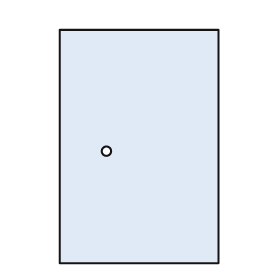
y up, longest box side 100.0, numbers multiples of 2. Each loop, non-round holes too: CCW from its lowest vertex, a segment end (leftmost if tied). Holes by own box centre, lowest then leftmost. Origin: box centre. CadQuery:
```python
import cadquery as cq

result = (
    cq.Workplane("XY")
    .moveTo(-34.0, -50.0)
    .lineTo(34.0, -50.0)
    .lineTo(34.0, 50.0)
    .lineTo(-34.0, 50.0)
    .close()
    .moveTo(-14.0, -2.0)
    .circle(2.0)
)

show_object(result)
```